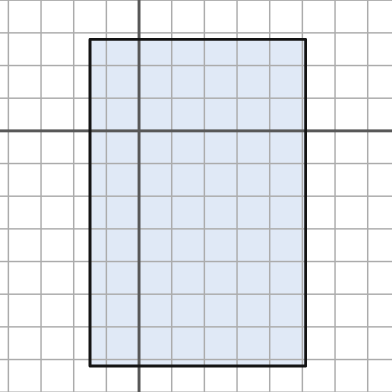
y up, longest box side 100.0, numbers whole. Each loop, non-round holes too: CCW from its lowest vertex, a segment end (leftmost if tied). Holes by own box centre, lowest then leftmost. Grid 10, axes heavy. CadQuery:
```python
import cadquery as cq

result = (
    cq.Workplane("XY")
    .moveTo(-15.0, -72.0)
    .lineTo(51.0, -72.0)
    .lineTo(51.0, 28.0)
    .lineTo(-15.0, 28.0)
    .close()
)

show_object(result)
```